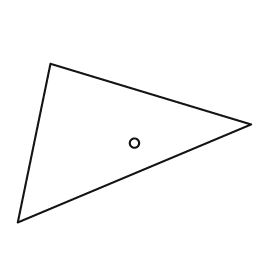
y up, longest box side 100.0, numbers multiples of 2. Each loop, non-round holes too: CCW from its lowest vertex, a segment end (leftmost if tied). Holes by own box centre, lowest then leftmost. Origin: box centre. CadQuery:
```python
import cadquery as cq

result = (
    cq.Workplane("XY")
    .moveTo(-50.0, -34.0)
    .lineTo(50.0, 8.0)
    .lineTo(-36.0, 34.0)
    .close()
    .moveTo(0.0, 0.0)
    .circle(2.0)
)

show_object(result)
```